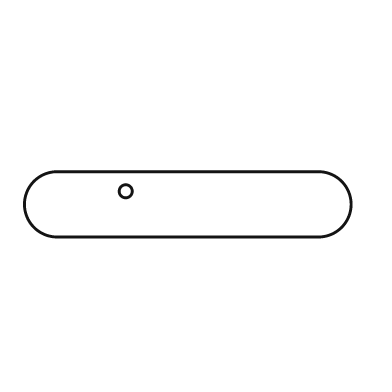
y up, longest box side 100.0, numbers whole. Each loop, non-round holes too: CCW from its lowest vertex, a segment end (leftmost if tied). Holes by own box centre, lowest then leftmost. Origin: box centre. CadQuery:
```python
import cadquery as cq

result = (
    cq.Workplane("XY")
    .moveTo(-40.0, -10.0)
    .lineTo(40.0, -10.0)
    .threePointArc((50.0, 0.0), (40.0, 10.0))
    .lineTo(-40.0, 10.0)
    .threePointArc((-50.0, 0.0), (-40.0, -10.0))
    .close()
    .moveTo(-19.0, 4.0)
    .circle(2.0)
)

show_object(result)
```